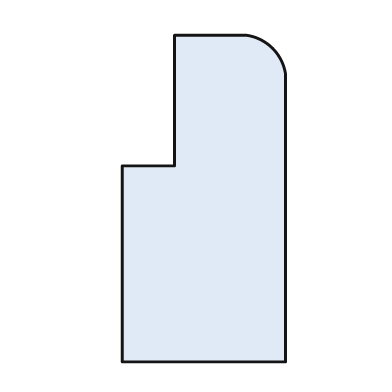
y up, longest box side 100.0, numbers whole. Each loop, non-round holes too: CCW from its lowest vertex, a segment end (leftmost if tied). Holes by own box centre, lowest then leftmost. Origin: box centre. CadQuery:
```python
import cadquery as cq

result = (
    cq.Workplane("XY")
    .moveTo(-25.0, -50.0)
    .lineTo(25.0, -50.0)
    .lineTo(25.0, 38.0)
    .threePointArc((21.0, 46.0), (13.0, 50.0))
    .lineTo(-9.0, 50.0)
    .lineTo(-9.0, 10.0)
    .lineTo(-25.0, 10.0)
    .close()
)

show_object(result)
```